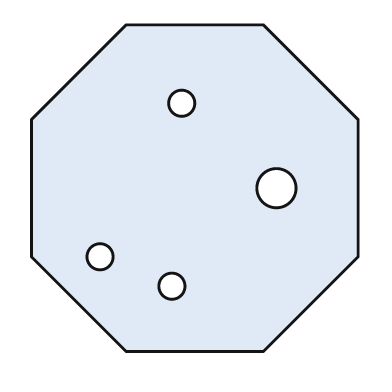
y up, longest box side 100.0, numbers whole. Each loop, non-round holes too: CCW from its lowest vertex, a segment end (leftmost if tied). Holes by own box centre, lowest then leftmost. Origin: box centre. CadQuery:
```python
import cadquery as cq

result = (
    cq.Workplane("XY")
    .moveTo(-21.0, -50.0)
    .lineTo(21.0, -50.0)
    .lineTo(50.0, -21.0)
    .lineTo(50.0, 21.0)
    .lineTo(21.0, 50.0)
    .lineTo(-21.0, 50.0)
    .lineTo(-50.0, 21.0)
    .lineTo(-50.0, -21.0)
    .close()
    .moveTo(-7.0, -30.0)
    .circle(4.0)
    .moveTo(-29.0, -21.0)
    .circle(4.0)
    .moveTo(25.0, 0.0)
    .circle(6.0)
    .moveTo(-4.0, 26.0)
    .circle(4.0)
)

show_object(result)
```